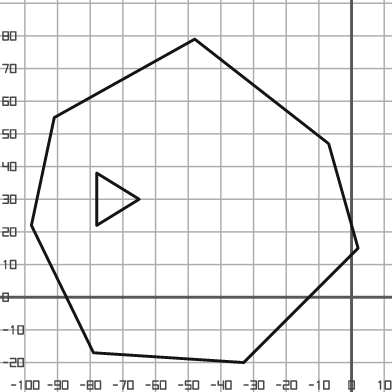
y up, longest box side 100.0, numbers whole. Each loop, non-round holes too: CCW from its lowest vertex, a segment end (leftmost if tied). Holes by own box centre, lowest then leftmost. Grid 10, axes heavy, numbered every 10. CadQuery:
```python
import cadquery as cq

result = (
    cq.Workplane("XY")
    .moveTo(-33.0, -20.0)
    .lineTo(2.0, 15.0)
    .lineTo(-7.0, 47.0)
    .lineTo(-48.0, 79.0)
    .lineTo(-91.0, 55.0)
    .lineTo(-98.0, 22.0)
    .lineTo(-79.0, -17.0)
    .close()
    .moveTo(-78.0, 22.0)
    .lineTo(-65.0, 30.0)
    .lineTo(-78.0, 38.0)
    .close()
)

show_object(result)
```